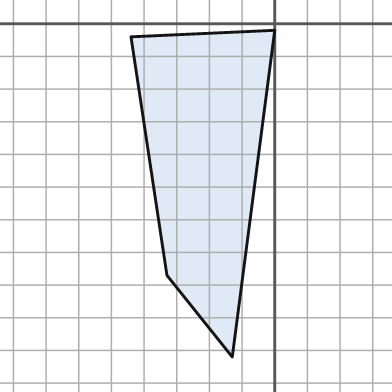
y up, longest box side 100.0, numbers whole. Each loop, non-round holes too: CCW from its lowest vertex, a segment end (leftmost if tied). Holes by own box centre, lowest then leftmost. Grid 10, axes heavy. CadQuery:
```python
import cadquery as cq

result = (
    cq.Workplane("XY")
    .moveTo(-13.0, -102.0)
    .lineTo(0.0, -2.0)
    .lineTo(-44.0, -4.0)
    .lineTo(-33.0, -77.0)
    .close()
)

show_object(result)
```